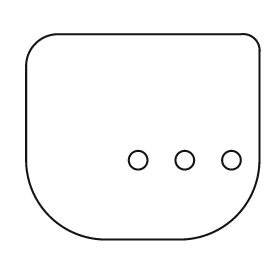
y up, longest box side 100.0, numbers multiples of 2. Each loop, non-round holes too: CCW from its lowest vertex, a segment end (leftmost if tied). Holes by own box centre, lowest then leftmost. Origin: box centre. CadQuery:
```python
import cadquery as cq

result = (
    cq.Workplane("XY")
    .moveTo(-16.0, -44.0)
    .lineTo(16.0, -44.0)
    .threePointArc((40.0, -34.0), (50.0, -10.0))
    .lineTo(50.0, 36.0)
    .threePointArc((48.0, 42.0), (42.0, 44.0))
    .lineTo(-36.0, 44.0)
    .threePointArc((-46.0, 40.0), (-50.0, 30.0))
    .lineTo(-50.0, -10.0)
    .threePointArc((-40.0, -34.0), (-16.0, -44.0))
    .close()
    .moveTo(-2.0, -10.0)
    .circle(4.0)
    .moveTo(18.0, -10.0)
    .circle(4.0)
    .moveTo(38.0, -10.0)
    .circle(4.0)
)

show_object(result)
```